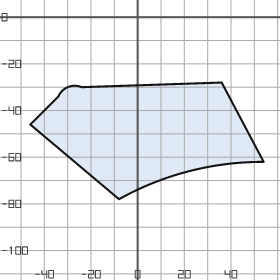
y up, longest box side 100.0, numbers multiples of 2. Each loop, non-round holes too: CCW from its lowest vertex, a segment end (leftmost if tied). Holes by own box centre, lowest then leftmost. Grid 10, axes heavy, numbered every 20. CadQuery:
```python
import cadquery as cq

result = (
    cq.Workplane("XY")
    .moveTo(-8.0, -78.0)
    .threePointArc((22.0, -66.0), (54.0, -62.0))
    .lineTo(36.0, -28.0)
    .lineTo(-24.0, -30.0)
    .threePointArc((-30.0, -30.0), (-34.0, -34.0))
    .lineTo(-46.0, -46.0)
    .close()
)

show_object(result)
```